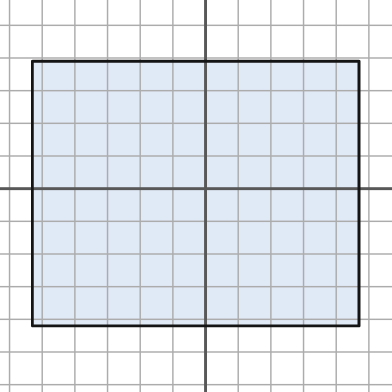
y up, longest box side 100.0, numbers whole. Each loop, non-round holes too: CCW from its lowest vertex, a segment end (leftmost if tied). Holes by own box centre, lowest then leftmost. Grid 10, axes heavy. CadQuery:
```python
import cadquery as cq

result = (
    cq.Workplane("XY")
    .moveTo(-53.0, -42.0)
    .lineTo(47.0, -42.0)
    .lineTo(47.0, 39.0)
    .lineTo(-53.0, 39.0)
    .close()
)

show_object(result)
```